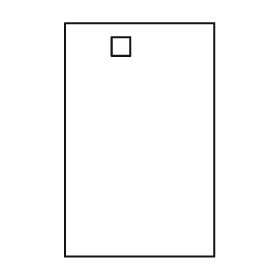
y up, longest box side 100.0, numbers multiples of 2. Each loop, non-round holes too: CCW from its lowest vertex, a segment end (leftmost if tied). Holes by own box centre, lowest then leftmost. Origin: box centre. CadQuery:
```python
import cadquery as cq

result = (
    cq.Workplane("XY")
    .moveTo(-32.0, -50.0)
    .lineTo(32.0, -50.0)
    .lineTo(32.0, 50.0)
    .lineTo(-32.0, 50.0)
    .close()
    .moveTo(-12.0, 36.0)
    .lineTo(-4.0, 36.0)
    .lineTo(-4.0, 44.0)
    .lineTo(-12.0, 44.0)
    .close()
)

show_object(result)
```